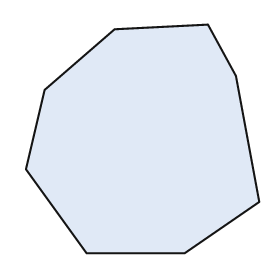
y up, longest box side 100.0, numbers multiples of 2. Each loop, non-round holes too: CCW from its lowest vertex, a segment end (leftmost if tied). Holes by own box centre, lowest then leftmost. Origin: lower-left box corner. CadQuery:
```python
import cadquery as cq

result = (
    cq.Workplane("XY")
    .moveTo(26.0, 0.0)
    .lineTo(68.0, 0.0)
    .lineTo(100.0, 22.0)
    .lineTo(90.0, 76.0)
    .lineTo(78.0, 98.0)
    .lineTo(38.0, 96.0)
    .lineTo(8.0, 70.0)
    .lineTo(0.0, 36.0)
    .close()
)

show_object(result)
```